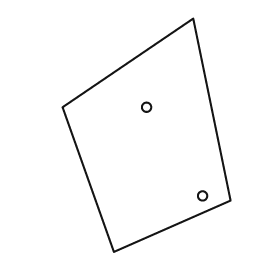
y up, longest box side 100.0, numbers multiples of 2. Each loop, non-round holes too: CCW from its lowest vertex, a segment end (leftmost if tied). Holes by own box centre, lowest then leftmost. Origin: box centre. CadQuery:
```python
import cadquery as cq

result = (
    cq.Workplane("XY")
    .moveTo(-14.0, -50.0)
    .lineTo(36.0, -28.0)
    .lineTo(20.0, 50.0)
    .lineTo(-36.0, 12.0)
    .close()
    .moveTo(24.0, -26.0)
    .circle(2.0)
    .moveTo(0.0, 12.0)
    .circle(2.0)
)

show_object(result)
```